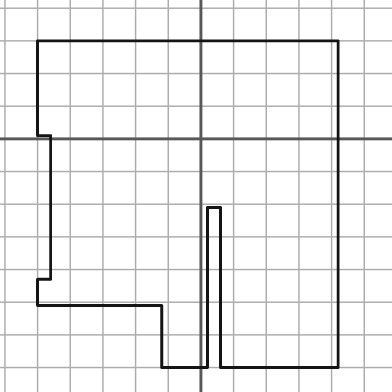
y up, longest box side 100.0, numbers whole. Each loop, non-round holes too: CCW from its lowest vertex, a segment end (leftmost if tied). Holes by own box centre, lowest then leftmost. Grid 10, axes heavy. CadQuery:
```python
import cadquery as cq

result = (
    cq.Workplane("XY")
    .moveTo(-12.0, -70.0)
    .lineTo(2.0, -70.0)
    .lineTo(2.0, -21.0)
    .lineTo(6.0, -21.0)
    .lineTo(6.0, -70.0)
    .lineTo(42.0, -70.0)
    .lineTo(42.0, 30.0)
    .lineTo(-50.0, 30.0)
    .lineTo(-50.0, 1.0)
    .lineTo(-46.0, 1.0)
    .lineTo(-46.0, -43.0)
    .lineTo(-50.0, -43.0)
    .lineTo(-50.0, -51.0)
    .lineTo(-12.0, -51.0)
    .close()
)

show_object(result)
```